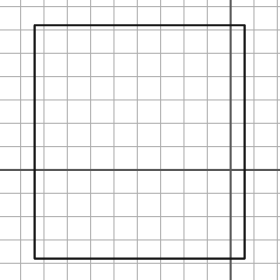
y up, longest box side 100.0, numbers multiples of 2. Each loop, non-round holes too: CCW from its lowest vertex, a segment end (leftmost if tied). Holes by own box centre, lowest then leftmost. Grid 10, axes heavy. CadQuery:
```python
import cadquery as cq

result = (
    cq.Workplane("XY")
    .moveTo(-84.0, -38.0)
    .lineTo(6.0, -38.0)
    .lineTo(6.0, 62.0)
    .lineTo(-84.0, 62.0)
    .close()
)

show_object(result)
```